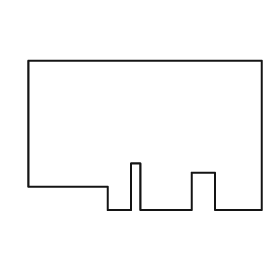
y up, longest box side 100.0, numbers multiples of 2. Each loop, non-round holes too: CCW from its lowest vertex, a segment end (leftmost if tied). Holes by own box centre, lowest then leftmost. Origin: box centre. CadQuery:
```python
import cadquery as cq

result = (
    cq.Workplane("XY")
    .moveTo(-16.0, -32.0)
    .lineTo(-6.0, -32.0)
    .lineTo(-6.0, -12.0)
    .lineTo(-2.0, -12.0)
    .lineTo(-2.0, -32.0)
    .lineTo(20.0, -32.0)
    .lineTo(20.0, -16.0)
    .lineTo(30.0, -16.0)
    .lineTo(30.0, -32.0)
    .lineTo(50.0, -32.0)
    .lineTo(50.0, 32.0)
    .lineTo(-50.0, 32.0)
    .lineTo(-50.0, -22.0)
    .lineTo(-16.0, -22.0)
    .close()
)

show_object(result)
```